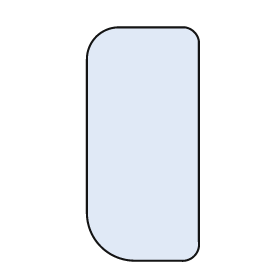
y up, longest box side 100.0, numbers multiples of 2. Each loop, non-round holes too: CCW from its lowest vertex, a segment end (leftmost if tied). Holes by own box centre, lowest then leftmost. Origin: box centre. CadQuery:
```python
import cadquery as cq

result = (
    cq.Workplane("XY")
    .moveTo(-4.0, -50.0)
    .lineTo(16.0, -50.0)
    .threePointArc((22.0, -48.0), (24.0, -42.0))
    .lineTo(24.0, 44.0)
    .threePointArc((22.0, 48.0), (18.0, 50.0))
    .lineTo(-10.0, 50.0)
    .threePointArc((-20.0, 46.0), (-24.0, 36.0))
    .lineTo(-24.0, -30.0)
    .threePointArc((-18.0, -44.0), (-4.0, -50.0))
    .close()
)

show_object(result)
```